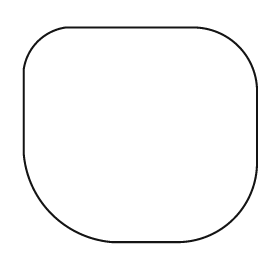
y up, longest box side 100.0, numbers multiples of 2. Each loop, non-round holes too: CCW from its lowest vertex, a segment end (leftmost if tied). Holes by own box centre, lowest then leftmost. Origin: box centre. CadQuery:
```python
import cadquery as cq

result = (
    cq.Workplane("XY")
    .moveTo(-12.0, -46.0)
    .lineTo(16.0, -46.0)
    .threePointArc((40.0, -36.0), (50.0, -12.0))
    .lineTo(50.0, 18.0)
    .threePointArc((42.0, 38.0), (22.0, 46.0))
    .lineTo(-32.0, 46.0)
    .threePointArc((-44.0, 40.0), (-50.0, 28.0))
    .lineTo(-50.0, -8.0)
    .threePointArc((-38.0, -34.0), (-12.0, -46.0))
    .close()
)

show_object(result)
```